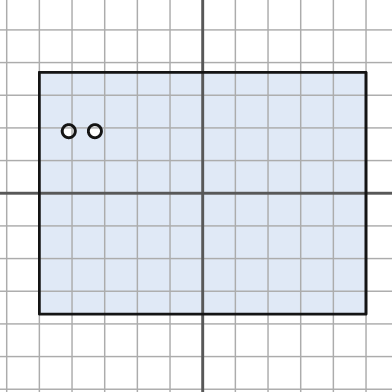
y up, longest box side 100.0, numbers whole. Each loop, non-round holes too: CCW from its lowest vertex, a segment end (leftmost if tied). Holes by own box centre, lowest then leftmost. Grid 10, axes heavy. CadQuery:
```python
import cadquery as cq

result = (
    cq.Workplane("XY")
    .moveTo(-50.0, -37.0)
    .lineTo(50.0, -37.0)
    .lineTo(50.0, 37.0)
    .lineTo(-50.0, 37.0)
    .close()
    .moveTo(-41.0, 19.0)
    .circle(2.0)
    .moveTo(-33.0, 19.0)
    .circle(2.0)
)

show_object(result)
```